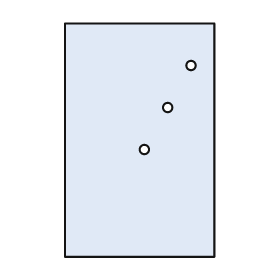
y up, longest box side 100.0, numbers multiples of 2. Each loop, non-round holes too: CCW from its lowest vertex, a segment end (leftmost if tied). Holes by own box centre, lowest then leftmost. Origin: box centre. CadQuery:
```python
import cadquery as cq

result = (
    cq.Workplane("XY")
    .moveTo(-32.0, -50.0)
    .lineTo(32.0, -50.0)
    .lineTo(32.0, 50.0)
    .lineTo(-32.0, 50.0)
    .close()
    .moveTo(2.0, -4.0)
    .circle(2.0)
    .moveTo(12.0, 14.0)
    .circle(2.0)
    .moveTo(22.0, 32.0)
    .circle(2.0)
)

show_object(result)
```